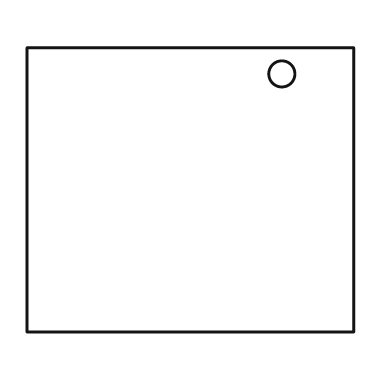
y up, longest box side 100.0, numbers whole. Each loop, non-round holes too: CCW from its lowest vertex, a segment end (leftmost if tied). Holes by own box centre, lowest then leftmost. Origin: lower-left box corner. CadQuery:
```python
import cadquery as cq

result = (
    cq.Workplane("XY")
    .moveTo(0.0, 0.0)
    .lineTo(100.0, 0.0)
    .lineTo(100.0, 87.0)
    .lineTo(0.0, 87.0)
    .close()
    .moveTo(78.0, 79.0)
    .circle(4.0)
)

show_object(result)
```